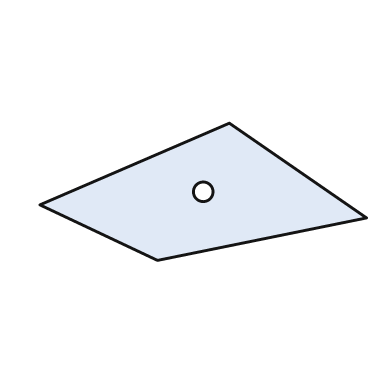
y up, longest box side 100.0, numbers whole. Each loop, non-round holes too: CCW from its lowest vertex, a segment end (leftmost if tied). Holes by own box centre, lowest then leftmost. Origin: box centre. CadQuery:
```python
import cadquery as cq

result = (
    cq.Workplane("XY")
    .moveTo(-14.0, -21.0)
    .lineTo(50.0, -8.0)
    .lineTo(8.0, 21.0)
    .lineTo(-50.0, -4.0)
    .close()
    .moveTo(0.0, 0.0)
    .circle(3.0)
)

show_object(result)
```